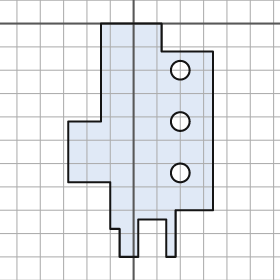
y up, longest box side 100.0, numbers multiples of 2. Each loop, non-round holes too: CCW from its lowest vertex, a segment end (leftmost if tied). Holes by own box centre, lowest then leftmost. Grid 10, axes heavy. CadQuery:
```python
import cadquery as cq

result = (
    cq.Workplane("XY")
    .moveTo(-6.0, -100.0)
    .lineTo(2.0, -100.0)
    .lineTo(2.0, -84.0)
    .lineTo(14.0, -84.0)
    .lineTo(14.0, -100.0)
    .lineTo(18.0, -100.0)
    .lineTo(18.0, -80.0)
    .lineTo(34.0, -80.0)
    .lineTo(34.0, -12.0)
    .lineTo(12.0, -12.0)
    .lineTo(12.0, 0.0)
    .lineTo(-14.0, 0.0)
    .lineTo(-14.0, -42.0)
    .lineTo(-28.0, -42.0)
    .lineTo(-28.0, -68.0)
    .lineTo(-10.0, -68.0)
    .lineTo(-10.0, -88.0)
    .lineTo(-6.0, -88.0)
    .close()
    .moveTo(20.0, -64.0)
    .circle(4.0)
    .moveTo(20.0, -42.0)
    .circle(4.0)
    .moveTo(20.0, -20.0)
    .circle(4.0)
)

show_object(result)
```